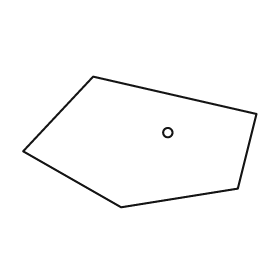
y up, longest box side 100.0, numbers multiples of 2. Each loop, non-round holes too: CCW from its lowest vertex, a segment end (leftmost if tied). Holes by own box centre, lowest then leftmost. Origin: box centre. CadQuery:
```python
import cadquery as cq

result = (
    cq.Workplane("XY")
    .moveTo(-8.0, -28.0)
    .lineTo(42.0, -20.0)
    .lineTo(50.0, 12.0)
    .lineTo(-20.0, 28.0)
    .lineTo(-50.0, -4.0)
    .close()
    .moveTo(12.0, 4.0)
    .circle(2.0)
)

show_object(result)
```